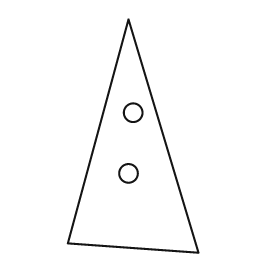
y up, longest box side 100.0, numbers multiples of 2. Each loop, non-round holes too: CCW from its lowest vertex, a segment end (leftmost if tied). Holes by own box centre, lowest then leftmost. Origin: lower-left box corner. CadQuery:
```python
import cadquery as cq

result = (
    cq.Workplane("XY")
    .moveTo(56.0, 0.0)
    .lineTo(26.0, 100.0)
    .lineTo(0.0, 4.0)
    .close()
    .moveTo(26.0, 34.0)
    .circle(4.0)
    .moveTo(28.0, 60.0)
    .circle(4.0)
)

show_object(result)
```